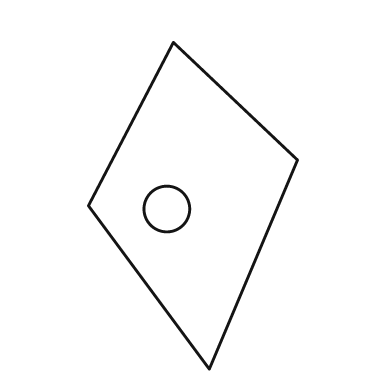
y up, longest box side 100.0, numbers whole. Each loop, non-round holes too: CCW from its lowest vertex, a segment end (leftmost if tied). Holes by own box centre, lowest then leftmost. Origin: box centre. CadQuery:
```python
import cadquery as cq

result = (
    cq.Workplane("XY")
    .moveTo(5.0, -50.0)
    .lineTo(32.0, 14.0)
    .lineTo(-6.0, 50.0)
    .lineTo(-32.0, 0.0)
    .close()
    .moveTo(-8.0, -1.0)
    .circle(7.0)
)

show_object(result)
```